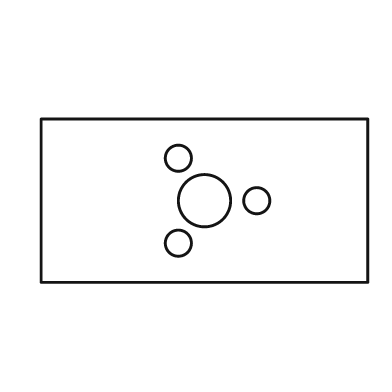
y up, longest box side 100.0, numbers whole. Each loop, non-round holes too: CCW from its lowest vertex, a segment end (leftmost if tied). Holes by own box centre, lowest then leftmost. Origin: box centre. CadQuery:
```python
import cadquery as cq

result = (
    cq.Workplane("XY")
    .moveTo(-50.0, -25.0)
    .lineTo(50.0, -25.0)
    .lineTo(50.0, 25.0)
    .lineTo(-50.0, 25.0)
    .close()
    .moveTo(-8.0, -13.0)
    .circle(4.0)
    .moveTo(0.0, 0.0)
    .circle(8.0)
    .moveTo(16.0, 0.0)
    .circle(4.0)
    .moveTo(-8.0, 13.0)
    .circle(4.0)
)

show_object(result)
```